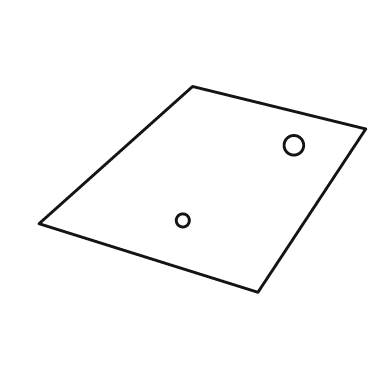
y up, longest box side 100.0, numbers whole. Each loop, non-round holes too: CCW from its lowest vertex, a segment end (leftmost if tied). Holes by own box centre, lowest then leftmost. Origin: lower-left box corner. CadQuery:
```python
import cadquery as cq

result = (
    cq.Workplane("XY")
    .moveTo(67.0, 0.0)
    .lineTo(100.0, 50.0)
    .lineTo(47.0, 63.0)
    .lineTo(0.0, 21.0)
    .close()
    .moveTo(44.0, 22.0)
    .circle(2.0)
    .moveTo(78.0, 45.0)
    .circle(3.0)
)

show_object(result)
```